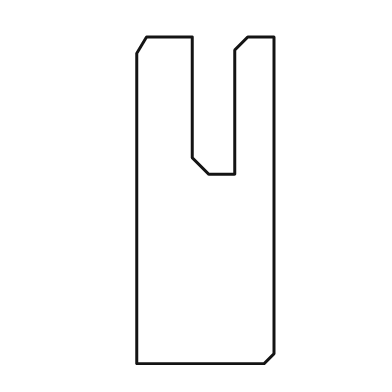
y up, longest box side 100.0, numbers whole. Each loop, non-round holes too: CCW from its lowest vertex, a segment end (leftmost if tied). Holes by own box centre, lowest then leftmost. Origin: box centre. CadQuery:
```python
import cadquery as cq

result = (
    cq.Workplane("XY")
    .moveTo(-21.0, -50.0)
    .lineTo(18.0, -50.0)
    .lineTo(21.0, -47.0)
    .lineTo(21.0, 50.0)
    .lineTo(13.0, 50.0)
    .lineTo(9.0, 46.0)
    .lineTo(9.0, 8.0)
    .lineTo(1.0, 8.0)
    .lineTo(-4.0, 13.0)
    .lineTo(-4.0, 50.0)
    .lineTo(-18.0, 50.0)
    .lineTo(-21.0, 45.0)
    .close()
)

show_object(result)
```